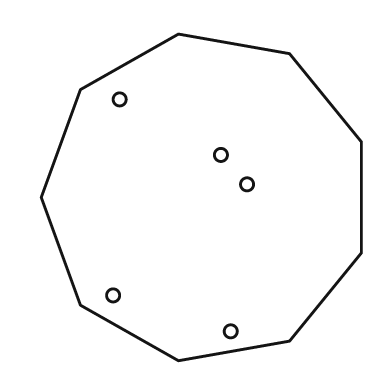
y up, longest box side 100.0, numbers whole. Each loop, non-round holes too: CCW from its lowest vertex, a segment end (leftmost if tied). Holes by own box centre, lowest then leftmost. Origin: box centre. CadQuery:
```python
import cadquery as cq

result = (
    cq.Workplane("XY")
    .moveTo(-7.0, -50.0)
    .lineTo(27.0, -44.0)
    .lineTo(49.0, -17.0)
    .lineTo(49.0, 17.0)
    .lineTo(27.0, 44.0)
    .lineTo(-7.0, 50.0)
    .lineTo(-37.0, 33.0)
    .lineTo(-49.0, 0.0)
    .lineTo(-37.0, -33.0)
    .close()
    .moveTo(9.0, -41.0)
    .circle(2.0)
    .moveTo(-27.0, -30.0)
    .circle(2.0)
    .moveTo(14.0, 4.0)
    .circle(2.0)
    .moveTo(6.0, 13.0)
    .circle(2.0)
    .moveTo(-25.0, 30.0)
    .circle(2.0)
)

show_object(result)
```